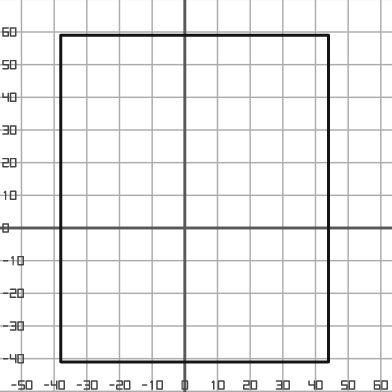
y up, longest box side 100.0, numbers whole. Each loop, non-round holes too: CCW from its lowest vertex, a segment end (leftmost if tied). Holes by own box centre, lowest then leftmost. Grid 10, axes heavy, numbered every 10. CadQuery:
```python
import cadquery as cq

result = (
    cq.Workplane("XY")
    .moveTo(-38.0, -41.0)
    .lineTo(44.0, -41.0)
    .lineTo(44.0, 59.0)
    .lineTo(-38.0, 59.0)
    .close()
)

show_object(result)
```